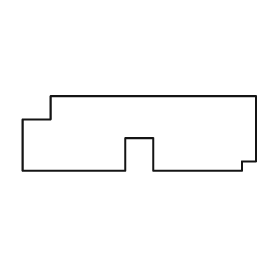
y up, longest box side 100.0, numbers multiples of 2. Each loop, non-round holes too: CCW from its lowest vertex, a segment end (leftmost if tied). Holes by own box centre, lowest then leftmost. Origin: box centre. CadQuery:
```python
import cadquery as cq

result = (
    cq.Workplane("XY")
    .moveTo(-50.0, -16.0)
    .lineTo(-6.0, -16.0)
    .lineTo(-6.0, -2.0)
    .lineTo(6.0, -2.0)
    .lineTo(6.0, -16.0)
    .lineTo(44.0, -16.0)
    .lineTo(44.0, -12.0)
    .lineTo(50.0, -12.0)
    .lineTo(50.0, 16.0)
    .lineTo(-38.0, 16.0)
    .lineTo(-38.0, 6.0)
    .lineTo(-50.0, 6.0)
    .close()
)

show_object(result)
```